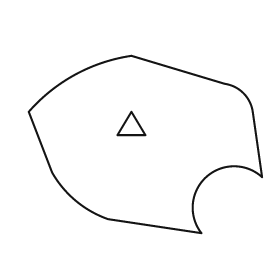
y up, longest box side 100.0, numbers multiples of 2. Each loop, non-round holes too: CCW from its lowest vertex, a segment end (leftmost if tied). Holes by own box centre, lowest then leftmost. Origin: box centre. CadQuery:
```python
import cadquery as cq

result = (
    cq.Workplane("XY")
    .moveTo(24.0, -38.0)
    .threePointArc((26.0, -14.0), (50.0, -14.0))
    .lineTo(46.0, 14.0)
    .threePointArc((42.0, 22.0), (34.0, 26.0))
    .lineTo(-6.0, 38.0)
    .threePointArc((-30.0, 30.0), (-50.0, 14.0))
    .lineTo(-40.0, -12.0)
    .threePointArc((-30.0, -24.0), (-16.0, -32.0))
    .close()
    .moveTo(-12.0, 4.0)
    .lineTo(0.0, 4.0)
    .lineTo(-6.0, 14.0)
    .close()
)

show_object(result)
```